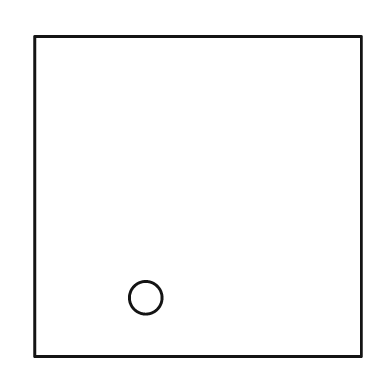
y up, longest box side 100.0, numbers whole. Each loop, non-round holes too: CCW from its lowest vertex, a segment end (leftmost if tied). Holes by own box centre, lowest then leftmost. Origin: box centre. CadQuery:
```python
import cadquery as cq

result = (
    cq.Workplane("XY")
    .moveTo(-50.0, -49.0)
    .lineTo(50.0, -49.0)
    .lineTo(50.0, 49.0)
    .lineTo(-50.0, 49.0)
    .close()
    .moveTo(-16.0, -31.0)
    .circle(5.0)
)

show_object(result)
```